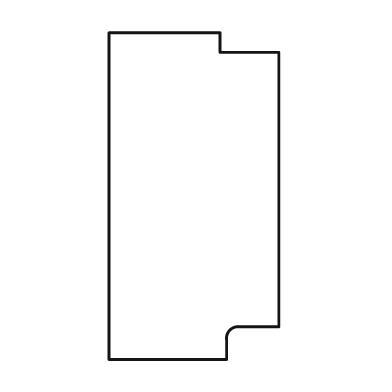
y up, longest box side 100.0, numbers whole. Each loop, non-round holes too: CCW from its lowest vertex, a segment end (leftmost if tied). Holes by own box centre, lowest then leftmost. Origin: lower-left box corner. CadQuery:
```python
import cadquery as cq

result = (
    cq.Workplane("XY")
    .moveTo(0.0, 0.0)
    .lineTo(36.0, 0.0)
    .lineTo(36.0, 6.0)
    .threePointArc((37.0, 9.0), (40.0, 10.0))
    .lineTo(52.0, 10.0)
    .lineTo(52.0, 94.0)
    .lineTo(34.0, 94.0)
    .lineTo(34.0, 100.0)
    .lineTo(0.0, 100.0)
    .close()
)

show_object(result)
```